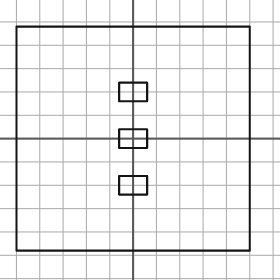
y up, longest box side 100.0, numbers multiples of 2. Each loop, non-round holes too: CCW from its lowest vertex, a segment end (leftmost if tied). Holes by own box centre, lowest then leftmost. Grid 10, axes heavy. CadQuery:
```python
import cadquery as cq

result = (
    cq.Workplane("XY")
    .moveTo(-50.0, -48.0)
    .lineTo(50.0, -48.0)
    .lineTo(50.0, 48.0)
    .lineTo(-50.0, 48.0)
    .close()
    .moveTo(-6.0, -24.0)
    .lineTo(6.0, -24.0)
    .lineTo(6.0, -16.0)
    .lineTo(-6.0, -16.0)
    .close()
    .moveTo(-6.0, -4.0)
    .lineTo(6.0, -4.0)
    .lineTo(6.0, 4.0)
    .lineTo(-6.0, 4.0)
    .close()
    .moveTo(-6.0, 16.0)
    .lineTo(6.0, 16.0)
    .lineTo(6.0, 24.0)
    .lineTo(-6.0, 24.0)
    .close()
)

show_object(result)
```